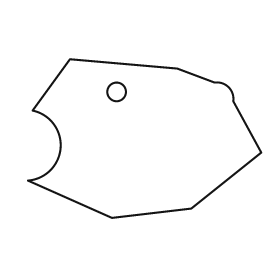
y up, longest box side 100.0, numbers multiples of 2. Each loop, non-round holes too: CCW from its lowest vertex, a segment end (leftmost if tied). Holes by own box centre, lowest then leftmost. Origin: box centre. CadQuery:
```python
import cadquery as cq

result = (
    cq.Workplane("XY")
    .moveTo(-14.0, -34.0)
    .lineTo(20.0, -30.0)
    .lineTo(50.0, -6.0)
    .lineTo(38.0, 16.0)
    .threePointArc((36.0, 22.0), (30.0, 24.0))
    .lineTo(14.0, 30.0)
    .lineTo(-32.0, 34.0)
    .lineTo(-48.0, 12.0)
    .threePointArc((-36.0, -4.0), (-50.0, -18.0))
    .close()
    .moveTo(-12.0, 20.0)
    .circle(4.0)
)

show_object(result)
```